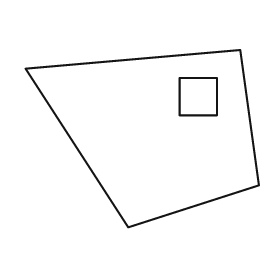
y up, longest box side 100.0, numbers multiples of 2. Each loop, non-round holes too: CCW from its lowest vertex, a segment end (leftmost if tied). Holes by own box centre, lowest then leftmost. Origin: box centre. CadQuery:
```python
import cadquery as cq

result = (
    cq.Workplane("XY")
    .moveTo(-6.0, -38.0)
    .lineTo(50.0, -20.0)
    .lineTo(42.0, 38.0)
    .lineTo(-50.0, 30.0)
    .close()
    .moveTo(16.0, 10.0)
    .lineTo(32.0, 10.0)
    .lineTo(32.0, 26.0)
    .lineTo(16.0, 26.0)
    .close()
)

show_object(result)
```